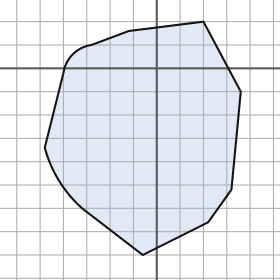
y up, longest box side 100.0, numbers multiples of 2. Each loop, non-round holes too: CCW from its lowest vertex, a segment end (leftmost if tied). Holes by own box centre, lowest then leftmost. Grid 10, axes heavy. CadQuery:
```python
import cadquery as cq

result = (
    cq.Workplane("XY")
    .moveTo(-6.0, -80.0)
    .lineTo(22.0, -66.0)
    .lineTo(32.0, -52.0)
    .lineTo(36.0, -10.0)
    .lineTo(20.0, 20.0)
    .lineTo(-12.0, 16.0)
    .lineTo(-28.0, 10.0)
    .threePointArc((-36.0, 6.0), (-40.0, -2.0))
    .lineTo(-48.0, -34.0)
    .threePointArc((-42.0, -48.0), (-32.0, -60.0))
    .close()
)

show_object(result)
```